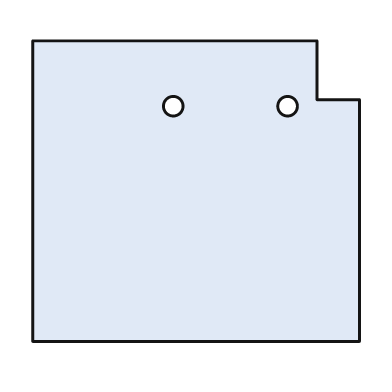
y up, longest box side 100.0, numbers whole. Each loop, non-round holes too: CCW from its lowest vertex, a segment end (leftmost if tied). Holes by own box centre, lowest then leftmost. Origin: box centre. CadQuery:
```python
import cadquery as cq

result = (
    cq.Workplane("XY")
    .moveTo(-50.0, -46.0)
    .lineTo(50.0, -46.0)
    .lineTo(50.0, 28.0)
    .lineTo(37.0, 28.0)
    .lineTo(37.0, 46.0)
    .lineTo(-50.0, 46.0)
    .close()
    .moveTo(-7.0, 26.0)
    .circle(3.0)
    .moveTo(28.0, 26.0)
    .circle(3.0)
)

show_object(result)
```